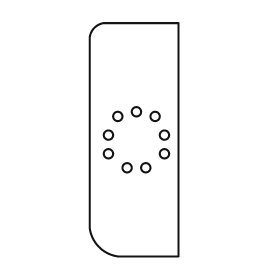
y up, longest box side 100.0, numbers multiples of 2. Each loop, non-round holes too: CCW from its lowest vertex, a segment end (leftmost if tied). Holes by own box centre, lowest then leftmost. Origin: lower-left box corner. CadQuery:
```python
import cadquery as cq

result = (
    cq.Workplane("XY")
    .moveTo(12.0, 0.0)
    .lineTo(38.0, 0.0)
    .lineTo(38.0, 100.0)
    .lineTo(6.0, 100.0)
    .threePointArc((2.0, 98.0), (0.0, 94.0))
    .lineTo(0.0, 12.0)
    .threePointArc((4.0, 4.0), (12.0, 0.0))
    .close()
    .moveTo(16.0, 38.0)
    .circle(2.0)
    .moveTo(24.0, 38.0)
    .circle(2.0)
    .moveTo(8.0, 44.0)
    .circle(2.0)
    .moveTo(32.0, 44.0)
    .circle(2.0)
    .moveTo(8.0, 52.0)
    .circle(2.0)
    .moveTo(32.0, 52.0)
    .circle(2.0)
    .moveTo(12.0, 60.0)
    .circle(2.0)
    .moveTo(28.0, 60.0)
    .circle(2.0)
    .moveTo(20.0, 62.0)
    .circle(2.0)
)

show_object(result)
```